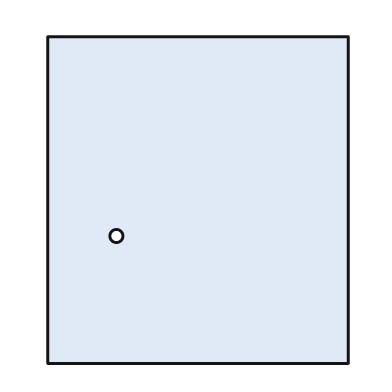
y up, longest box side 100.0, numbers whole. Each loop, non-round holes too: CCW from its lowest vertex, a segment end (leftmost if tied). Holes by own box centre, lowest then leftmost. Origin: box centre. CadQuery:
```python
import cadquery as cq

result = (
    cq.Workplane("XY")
    .moveTo(-46.0, -50.0)
    .lineTo(46.0, -50.0)
    .lineTo(46.0, 50.0)
    .lineTo(-46.0, 50.0)
    .close()
    .moveTo(-25.0, -11.0)
    .circle(2.0)
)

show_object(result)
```